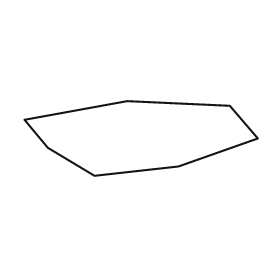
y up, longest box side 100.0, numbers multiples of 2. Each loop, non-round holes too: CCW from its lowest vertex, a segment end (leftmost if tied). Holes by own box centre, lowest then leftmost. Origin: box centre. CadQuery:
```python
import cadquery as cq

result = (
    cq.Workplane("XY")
    .moveTo(-20.0, -16.0)
    .lineTo(16.0, -12.0)
    .lineTo(50.0, 0.0)
    .lineTo(38.0, 14.0)
    .lineTo(-6.0, 16.0)
    .lineTo(-50.0, 8.0)
    .lineTo(-40.0, -4.0)
    .close()
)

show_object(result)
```